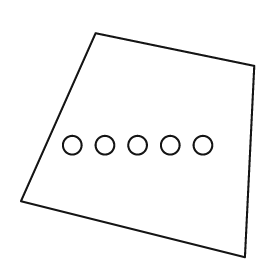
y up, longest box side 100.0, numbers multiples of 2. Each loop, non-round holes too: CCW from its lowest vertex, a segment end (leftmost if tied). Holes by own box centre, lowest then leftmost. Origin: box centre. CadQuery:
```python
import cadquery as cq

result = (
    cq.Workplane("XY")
    .moveTo(46.0, -48.0)
    .lineTo(50.0, 34.0)
    .lineTo(-18.0, 48.0)
    .lineTo(-50.0, -24.0)
    .close()
    .moveTo(-28.0, 0.0)
    .circle(4.0)
    .moveTo(-14.0, 0.0)
    .circle(4.0)
    .moveTo(0.0, 0.0)
    .circle(4.0)
    .moveTo(14.0, 0.0)
    .circle(4.0)
    .moveTo(28.0, 0.0)
    .circle(4.0)
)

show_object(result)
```